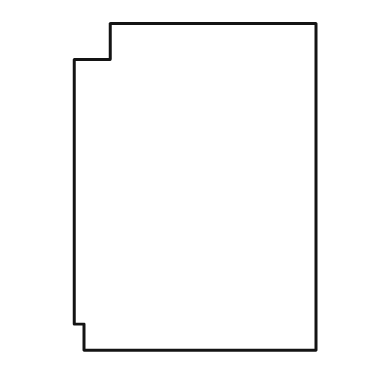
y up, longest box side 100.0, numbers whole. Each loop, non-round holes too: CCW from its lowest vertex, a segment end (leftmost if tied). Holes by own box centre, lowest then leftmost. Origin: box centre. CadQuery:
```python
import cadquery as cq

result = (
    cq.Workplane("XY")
    .moveTo(-34.0, -50.0)
    .lineTo(37.0, -50.0)
    .lineTo(37.0, 50.0)
    .lineTo(-26.0, 50.0)
    .lineTo(-26.0, 39.0)
    .lineTo(-37.0, 39.0)
    .lineTo(-37.0, -42.0)
    .lineTo(-34.0, -42.0)
    .close()
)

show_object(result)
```